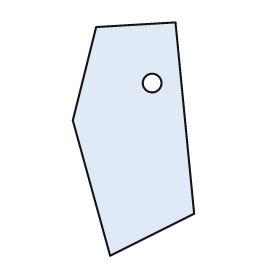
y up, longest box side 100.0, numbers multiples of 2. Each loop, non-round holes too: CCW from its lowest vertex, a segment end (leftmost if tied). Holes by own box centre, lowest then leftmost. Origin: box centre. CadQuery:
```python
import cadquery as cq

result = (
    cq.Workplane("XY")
    .moveTo(-10.0, -50.0)
    .lineTo(26.0, -32.0)
    .lineTo(18.0, 50.0)
    .lineTo(-16.0, 48.0)
    .lineTo(-26.0, 8.0)
    .close()
    .moveTo(8.0, 24.0)
    .circle(4.0)
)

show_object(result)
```